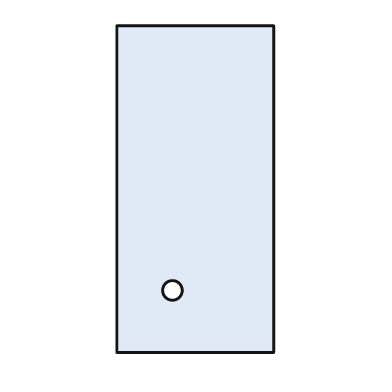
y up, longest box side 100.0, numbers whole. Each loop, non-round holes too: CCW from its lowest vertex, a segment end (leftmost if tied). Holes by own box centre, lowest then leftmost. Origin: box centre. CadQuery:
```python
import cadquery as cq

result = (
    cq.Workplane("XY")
    .moveTo(-24.0, -50.0)
    .lineTo(24.0, -50.0)
    .lineTo(24.0, 50.0)
    .lineTo(-24.0, 50.0)
    .close()
    .moveTo(-7.0, -31.0)
    .circle(3.0)
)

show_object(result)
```